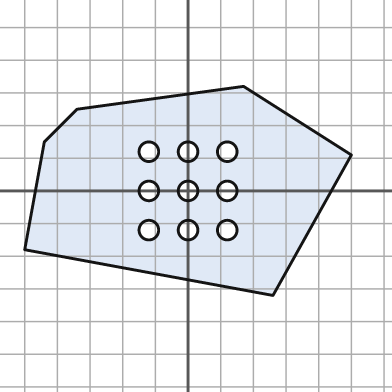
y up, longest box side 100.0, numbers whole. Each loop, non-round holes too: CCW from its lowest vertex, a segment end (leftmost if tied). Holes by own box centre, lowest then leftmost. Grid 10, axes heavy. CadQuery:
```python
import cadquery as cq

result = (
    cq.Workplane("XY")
    .moveTo(26.0, -32.0)
    .lineTo(50.0, 11.0)
    .lineTo(17.0, 32.0)
    .lineTo(-34.0, 25.0)
    .lineTo(-44.0, 15.0)
    .lineTo(-50.0, -18.0)
    .close()
    .moveTo(-12.0, -12.0)
    .circle(3.0)
    .moveTo(0.0, -12.0)
    .circle(3.0)
    .moveTo(12.0, -12.0)
    .circle(3.0)
    .moveTo(-12.0, 0.0)
    .circle(3.0)
    .moveTo(0.0, 0.0)
    .circle(3.0)
    .moveTo(12.0, 0.0)
    .circle(3.0)
    .moveTo(-12.0, 12.0)
    .circle(3.0)
    .moveTo(0.0, 12.0)
    .circle(3.0)
    .moveTo(12.0, 12.0)
    .circle(3.0)
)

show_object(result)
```